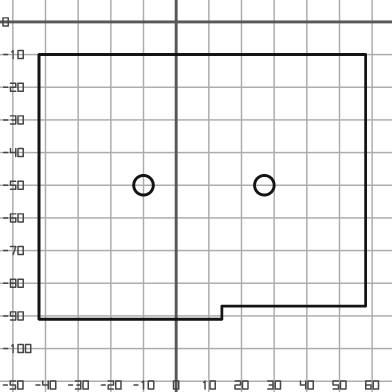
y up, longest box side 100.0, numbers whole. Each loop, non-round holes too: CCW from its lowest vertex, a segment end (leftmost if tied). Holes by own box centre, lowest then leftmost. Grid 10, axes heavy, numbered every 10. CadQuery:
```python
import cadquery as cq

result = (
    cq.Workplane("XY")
    .moveTo(-42.0, -91.0)
    .lineTo(14.0, -91.0)
    .lineTo(14.0, -87.0)
    .lineTo(58.0, -87.0)
    .lineTo(58.0, -10.0)
    .lineTo(-42.0, -10.0)
    .close()
    .moveTo(-10.0, -50.0)
    .circle(3.0)
    .moveTo(27.0, -50.0)
    .circle(3.0)
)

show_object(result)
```